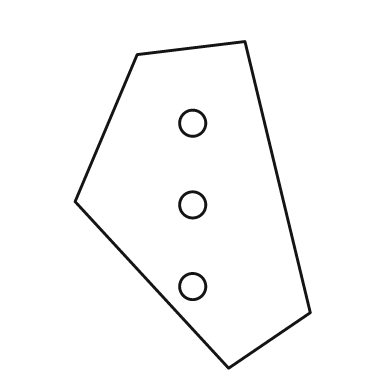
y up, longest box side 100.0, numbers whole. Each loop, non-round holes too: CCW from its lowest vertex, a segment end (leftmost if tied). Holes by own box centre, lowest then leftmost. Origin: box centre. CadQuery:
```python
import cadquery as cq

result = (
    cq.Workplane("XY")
    .moveTo(11.0, -50.0)
    .lineTo(36.0, -33.0)
    .lineTo(16.0, 50.0)
    .lineTo(-17.0, 46.0)
    .lineTo(-36.0, 1.0)
    .close()
    .moveTo(0.0, -25.0)
    .circle(4.0)
    .moveTo(0.0, 0.0)
    .circle(4.0)
    .moveTo(0.0, 25.0)
    .circle(4.0)
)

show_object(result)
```